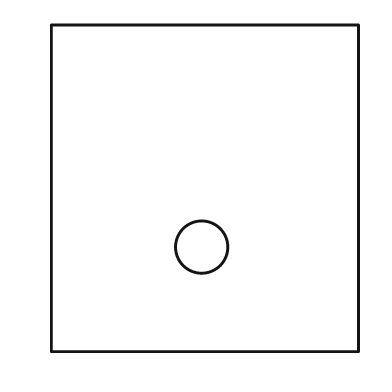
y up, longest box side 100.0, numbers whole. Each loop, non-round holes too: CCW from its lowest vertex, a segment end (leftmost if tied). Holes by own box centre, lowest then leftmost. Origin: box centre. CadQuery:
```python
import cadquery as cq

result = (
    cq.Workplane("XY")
    .moveTo(-47.0, -50.0)
    .lineTo(47.0, -50.0)
    .lineTo(47.0, 50.0)
    .lineTo(-47.0, 50.0)
    .close()
    .moveTo(-1.0, -18.0)
    .circle(8.0)
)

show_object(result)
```